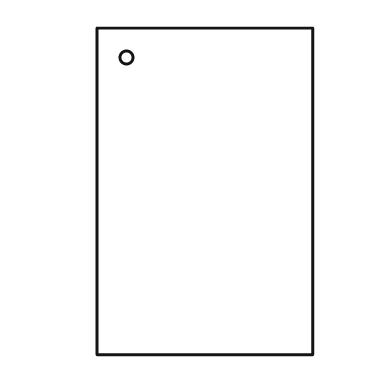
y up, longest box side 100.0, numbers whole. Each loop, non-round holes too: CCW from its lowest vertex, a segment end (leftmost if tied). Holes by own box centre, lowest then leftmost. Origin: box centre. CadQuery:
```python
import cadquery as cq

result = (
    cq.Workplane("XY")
    .moveTo(-33.0, -50.0)
    .lineTo(33.0, -50.0)
    .lineTo(33.0, 50.0)
    .lineTo(-33.0, 50.0)
    .close()
    .moveTo(-24.0, 41.0)
    .circle(2.0)
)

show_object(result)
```